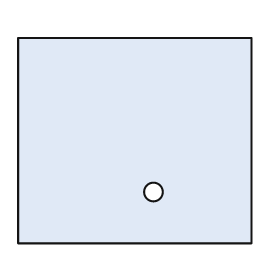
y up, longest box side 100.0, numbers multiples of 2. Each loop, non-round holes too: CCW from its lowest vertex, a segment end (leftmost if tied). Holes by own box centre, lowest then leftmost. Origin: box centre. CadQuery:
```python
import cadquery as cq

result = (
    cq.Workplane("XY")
    .moveTo(-50.0, -44.0)
    .lineTo(50.0, -44.0)
    .lineTo(50.0, 44.0)
    .lineTo(-50.0, 44.0)
    .close()
    .moveTo(8.0, -22.0)
    .circle(4.0)
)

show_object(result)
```